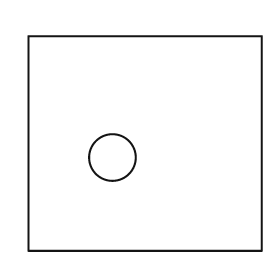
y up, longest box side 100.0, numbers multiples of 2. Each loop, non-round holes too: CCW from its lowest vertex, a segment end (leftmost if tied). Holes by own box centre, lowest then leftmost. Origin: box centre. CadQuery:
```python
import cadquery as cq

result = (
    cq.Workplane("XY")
    .moveTo(-50.0, -46.0)
    .lineTo(50.0, -46.0)
    .lineTo(50.0, 46.0)
    .lineTo(-50.0, 46.0)
    .close()
    .moveTo(-14.0, -6.0)
    .circle(10.0)
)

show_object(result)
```